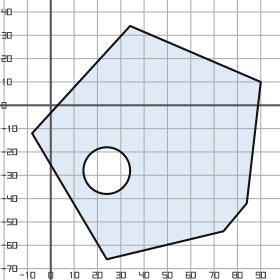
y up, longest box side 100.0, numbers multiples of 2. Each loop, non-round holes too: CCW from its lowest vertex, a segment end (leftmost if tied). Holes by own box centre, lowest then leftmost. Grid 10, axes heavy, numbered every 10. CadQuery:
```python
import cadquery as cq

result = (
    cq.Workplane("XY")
    .moveTo(24.0, -66.0)
    .lineTo(74.0, -54.0)
    .lineTo(84.0, -42.0)
    .lineTo(90.0, 10.0)
    .lineTo(34.0, 34.0)
    .lineTo(-8.0, -12.0)
    .close()
    .moveTo(24.0, -28.0)
    .circle(10.0)
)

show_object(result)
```